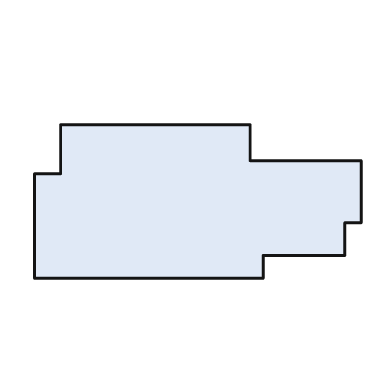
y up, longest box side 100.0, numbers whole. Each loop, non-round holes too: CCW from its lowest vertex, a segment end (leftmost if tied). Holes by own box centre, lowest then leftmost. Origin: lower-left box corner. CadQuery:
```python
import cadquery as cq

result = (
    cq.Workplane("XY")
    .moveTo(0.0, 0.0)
    .lineTo(70.0, 0.0)
    .lineTo(70.0, 7.0)
    .lineTo(95.0, 7.0)
    .lineTo(95.0, 17.0)
    .lineTo(100.0, 17.0)
    .lineTo(100.0, 36.0)
    .lineTo(66.0, 36.0)
    .lineTo(66.0, 47.0)
    .lineTo(8.0, 47.0)
    .lineTo(8.0, 32.0)
    .lineTo(0.0, 32.0)
    .close()
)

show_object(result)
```